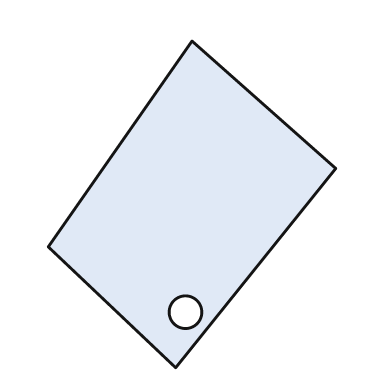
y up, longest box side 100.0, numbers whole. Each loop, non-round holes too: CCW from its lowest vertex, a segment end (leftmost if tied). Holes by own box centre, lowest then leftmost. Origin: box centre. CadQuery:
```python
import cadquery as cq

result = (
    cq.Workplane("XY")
    .moveTo(-5.0, -50.0)
    .lineTo(44.0, 11.0)
    .lineTo(0.0, 50.0)
    .lineTo(-44.0, -13.0)
    .close()
    .moveTo(-2.0, -33.0)
    .circle(5.0)
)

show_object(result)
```